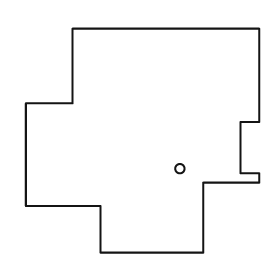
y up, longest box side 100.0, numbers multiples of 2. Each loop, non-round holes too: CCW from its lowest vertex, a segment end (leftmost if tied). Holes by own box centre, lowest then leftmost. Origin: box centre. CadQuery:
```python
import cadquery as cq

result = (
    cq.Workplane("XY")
    .moveTo(-18.0, -48.0)
    .lineTo(26.0, -48.0)
    .lineTo(26.0, -18.0)
    .lineTo(50.0, -18.0)
    .lineTo(50.0, -14.0)
    .lineTo(42.0, -14.0)
    .lineTo(42.0, 8.0)
    .lineTo(50.0, 8.0)
    .lineTo(50.0, 48.0)
    .lineTo(-30.0, 48.0)
    .lineTo(-30.0, 16.0)
    .lineTo(-50.0, 16.0)
    .lineTo(-50.0, -28.0)
    .lineTo(-18.0, -28.0)
    .close()
    .moveTo(16.0, -12.0)
    .circle(2.0)
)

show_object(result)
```